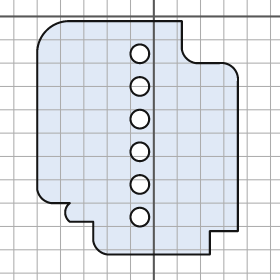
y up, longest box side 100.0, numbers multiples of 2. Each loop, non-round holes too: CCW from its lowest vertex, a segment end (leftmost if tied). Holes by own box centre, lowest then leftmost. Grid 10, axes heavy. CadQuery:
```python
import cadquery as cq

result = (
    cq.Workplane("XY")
    .moveTo(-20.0, -102.0)
    .lineTo(24.0, -102.0)
    .lineTo(24.0, -92.0)
    .lineTo(36.0, -92.0)
    .lineTo(36.0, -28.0)
    .threePointArc((34.0, -22.0), (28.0, -20.0))
    .lineTo(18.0, -20.0)
    .threePointArc((14.0, -18.0), (12.0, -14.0))
    .lineTo(12.0, -2.0)
    .lineTo(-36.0, -2.0)
    .threePointArc((-46.0, -6.0), (-50.0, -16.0))
    .lineTo(-50.0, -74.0)
    .threePointArc((-48.0, -78.0), (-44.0, -80.0))
    .lineTo(-36.0, -80.0)
    .threePointArc((-38.0, -84.0), (-36.0, -88.0))
    .lineTo(-26.0, -88.0)
    .lineTo(-26.0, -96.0)
    .threePointArc((-24.0, -100.0), (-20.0, -102.0))
    .close()
    .moveTo(-6.0, -86.0)
    .circle(4.0)
    .moveTo(-6.0, -72.0)
    .circle(4.0)
    .moveTo(-6.0, -58.0)
    .circle(4.0)
    .moveTo(-6.0, -44.0)
    .circle(4.0)
    .moveTo(-6.0, -30.0)
    .circle(4.0)
    .moveTo(-6.0, -16.0)
    .circle(4.0)
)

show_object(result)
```